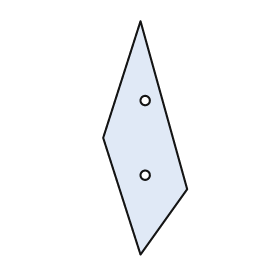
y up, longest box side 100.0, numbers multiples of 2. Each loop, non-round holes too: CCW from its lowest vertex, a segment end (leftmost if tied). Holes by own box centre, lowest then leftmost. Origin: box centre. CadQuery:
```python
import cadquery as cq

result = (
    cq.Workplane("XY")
    .moveTo(-2.0, -50.0)
    .lineTo(18.0, -22.0)
    .lineTo(-2.0, 50.0)
    .lineTo(-18.0, 0.0)
    .close()
    .moveTo(0.0, -16.0)
    .circle(2.0)
    .moveTo(0.0, 16.0)
    .circle(2.0)
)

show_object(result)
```